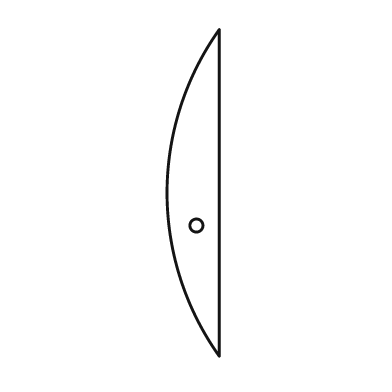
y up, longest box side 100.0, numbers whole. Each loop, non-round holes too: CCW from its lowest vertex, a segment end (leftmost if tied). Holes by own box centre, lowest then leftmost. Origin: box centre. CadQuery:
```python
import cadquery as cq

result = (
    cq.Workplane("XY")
    .moveTo(8.0, -50.0)
    .lineTo(8.0, 50.0)
    .threePointArc((-8.0, 0.0), (8.0, -50.0))
    .close()
    .moveTo(1.0, -10.0)
    .circle(2.0)
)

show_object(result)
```